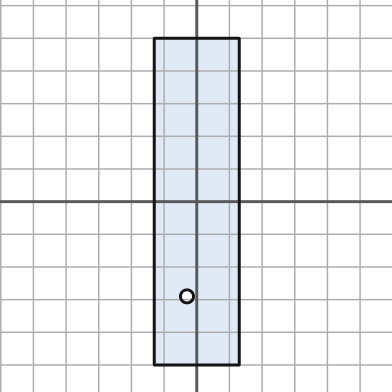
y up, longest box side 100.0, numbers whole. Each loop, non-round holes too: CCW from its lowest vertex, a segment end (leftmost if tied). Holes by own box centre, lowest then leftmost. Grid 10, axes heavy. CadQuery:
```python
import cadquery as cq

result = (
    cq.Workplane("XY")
    .moveTo(-13.0, -50.0)
    .lineTo(13.0, -50.0)
    .lineTo(13.0, 50.0)
    .lineTo(-13.0, 50.0)
    .close()
    .moveTo(-3.0, -29.0)
    .circle(2.0)
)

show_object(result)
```